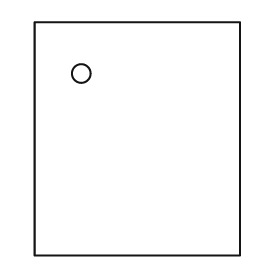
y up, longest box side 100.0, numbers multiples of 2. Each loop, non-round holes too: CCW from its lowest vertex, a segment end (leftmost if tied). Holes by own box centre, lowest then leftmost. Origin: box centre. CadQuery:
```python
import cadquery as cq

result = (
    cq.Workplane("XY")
    .moveTo(-44.0, -50.0)
    .lineTo(44.0, -50.0)
    .lineTo(44.0, 50.0)
    .lineTo(-44.0, 50.0)
    .close()
    .moveTo(-24.0, 28.0)
    .circle(4.0)
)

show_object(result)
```